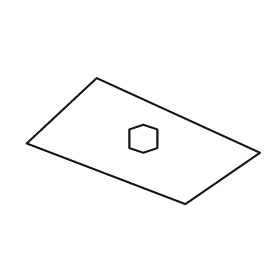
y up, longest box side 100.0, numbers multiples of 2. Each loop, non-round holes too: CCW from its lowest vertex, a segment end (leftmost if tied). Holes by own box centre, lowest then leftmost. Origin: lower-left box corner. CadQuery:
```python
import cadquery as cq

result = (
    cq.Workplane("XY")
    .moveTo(68.0, 0.0)
    .lineTo(100.0, 22.0)
    .lineTo(30.0, 54.0)
    .lineTo(0.0, 26.0)
    .close()
    .moveTo(50.0, 22.0)
    .lineTo(56.0, 24.0)
    .lineTo(56.0, 32.0)
    .lineTo(50.0, 34.0)
    .lineTo(44.0, 32.0)
    .lineTo(44.0, 24.0)
    .close()
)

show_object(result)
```